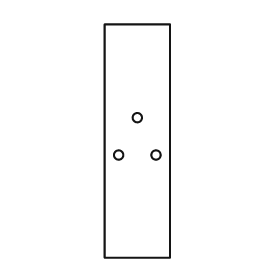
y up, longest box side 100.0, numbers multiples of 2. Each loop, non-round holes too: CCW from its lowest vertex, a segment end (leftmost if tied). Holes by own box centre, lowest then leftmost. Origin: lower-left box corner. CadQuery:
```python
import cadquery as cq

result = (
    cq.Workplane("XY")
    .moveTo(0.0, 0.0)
    .lineTo(28.0, 0.0)
    .lineTo(28.0, 100.0)
    .lineTo(0.0, 100.0)
    .close()
    .moveTo(6.0, 44.0)
    .circle(2.0)
    .moveTo(22.0, 44.0)
    .circle(2.0)
    .moveTo(14.0, 60.0)
    .circle(2.0)
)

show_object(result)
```